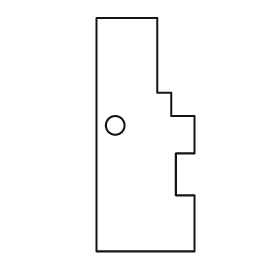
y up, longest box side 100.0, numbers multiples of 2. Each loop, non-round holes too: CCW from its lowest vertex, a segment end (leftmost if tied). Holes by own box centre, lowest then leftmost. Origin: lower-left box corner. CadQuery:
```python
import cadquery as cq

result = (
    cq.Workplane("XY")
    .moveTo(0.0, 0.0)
    .lineTo(42.0, 0.0)
    .lineTo(42.0, 24.0)
    .lineTo(34.0, 24.0)
    .lineTo(34.0, 42.0)
    .lineTo(42.0, 42.0)
    .lineTo(42.0, 58.0)
    .lineTo(32.0, 58.0)
    .lineTo(32.0, 68.0)
    .lineTo(26.0, 68.0)
    .lineTo(26.0, 100.0)
    .lineTo(0.0, 100.0)
    .close()
    .moveTo(8.0, 54.0)
    .circle(4.0)
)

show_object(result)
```